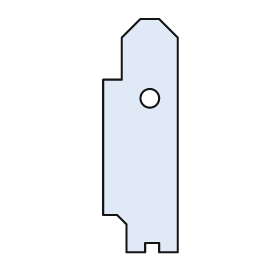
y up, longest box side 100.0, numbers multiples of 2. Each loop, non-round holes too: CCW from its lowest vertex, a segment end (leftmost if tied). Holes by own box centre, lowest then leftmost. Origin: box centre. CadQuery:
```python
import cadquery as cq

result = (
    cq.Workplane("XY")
    .moveTo(-6.0, -50.0)
    .lineTo(2.0, -50.0)
    .lineTo(2.0, -46.0)
    .lineTo(8.0, -46.0)
    .lineTo(8.0, -50.0)
    .lineTo(16.0, -50.0)
    .lineTo(16.0, 42.0)
    .lineTo(8.0, 50.0)
    .lineTo(0.0, 50.0)
    .lineTo(-8.0, 42.0)
    .lineTo(-8.0, 24.0)
    .lineTo(-16.0, 24.0)
    .lineTo(-16.0, -34.0)
    .lineTo(-10.0, -34.0)
    .lineTo(-6.0, -38.0)
    .close()
    .moveTo(4.0, 16.0)
    .circle(4.0)
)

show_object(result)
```